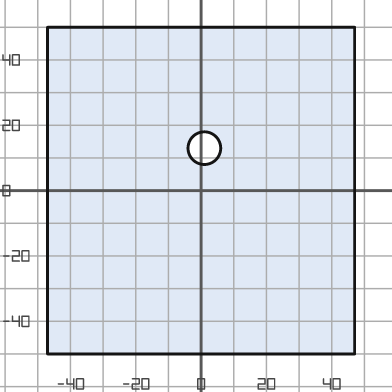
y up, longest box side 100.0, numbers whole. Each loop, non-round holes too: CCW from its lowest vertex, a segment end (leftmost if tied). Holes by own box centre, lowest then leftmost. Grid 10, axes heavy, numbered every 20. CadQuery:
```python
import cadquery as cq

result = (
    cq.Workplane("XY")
    .moveTo(-47.0, -50.0)
    .lineTo(47.0, -50.0)
    .lineTo(47.0, 50.0)
    .lineTo(-47.0, 50.0)
    .close()
    .moveTo(1.0, 13.0)
    .circle(5.0)
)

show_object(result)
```